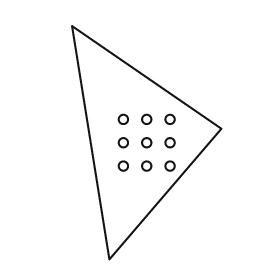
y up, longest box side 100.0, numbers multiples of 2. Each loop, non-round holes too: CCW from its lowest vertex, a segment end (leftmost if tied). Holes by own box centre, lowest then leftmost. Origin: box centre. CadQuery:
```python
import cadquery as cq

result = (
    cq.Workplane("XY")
    .moveTo(-16.0, -50.0)
    .lineTo(32.0, 6.0)
    .lineTo(-32.0, 50.0)
    .close()
    .moveTo(-10.0, -10.0)
    .circle(2.0)
    .moveTo(0.0, -10.0)
    .circle(2.0)
    .moveTo(10.0, -10.0)
    .circle(2.0)
    .moveTo(-10.0, 0.0)
    .circle(2.0)
    .moveTo(0.0, 0.0)
    .circle(2.0)
    .moveTo(10.0, 0.0)
    .circle(2.0)
    .moveTo(-10.0, 10.0)
    .circle(2.0)
    .moveTo(0.0, 10.0)
    .circle(2.0)
    .moveTo(10.0, 10.0)
    .circle(2.0)
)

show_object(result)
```